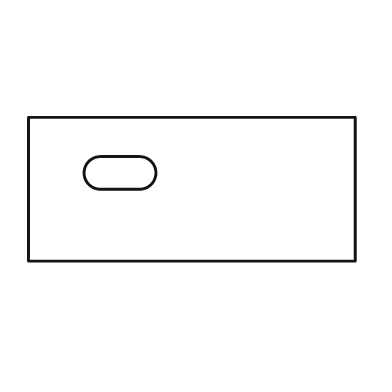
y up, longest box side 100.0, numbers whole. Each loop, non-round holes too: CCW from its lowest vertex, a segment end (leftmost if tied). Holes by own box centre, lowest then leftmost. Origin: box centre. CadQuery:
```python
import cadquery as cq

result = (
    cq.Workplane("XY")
    .moveTo(-50.0, -22.0)
    .lineTo(50.0, -22.0)
    .lineTo(50.0, 22.0)
    .lineTo(-50.0, 22.0)
    .close()
    .moveTo(-28.0, 0.0)
    .lineTo(-16.0, 0.0)
    .threePointArc((-11.0, 5.0), (-16.0, 10.0))
    .lineTo(-28.0, 10.0)
    .threePointArc((-33.0, 5.0), (-28.0, 0.0))
    .close()
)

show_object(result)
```